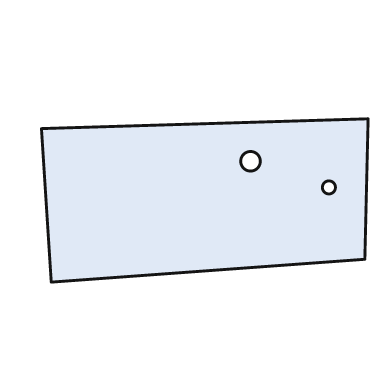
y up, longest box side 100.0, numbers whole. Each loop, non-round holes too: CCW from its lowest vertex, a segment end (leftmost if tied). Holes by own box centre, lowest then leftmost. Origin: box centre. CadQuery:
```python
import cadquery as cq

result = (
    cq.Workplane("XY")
    .moveTo(-47.0, -25.0)
    .lineTo(49.0, -18.0)
    .lineTo(50.0, 25.0)
    .lineTo(-50.0, 22.0)
    .close()
    .moveTo(38.0, 4.0)
    .circle(2.0)
    .moveTo(14.0, 12.0)
    .circle(3.0)
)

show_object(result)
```